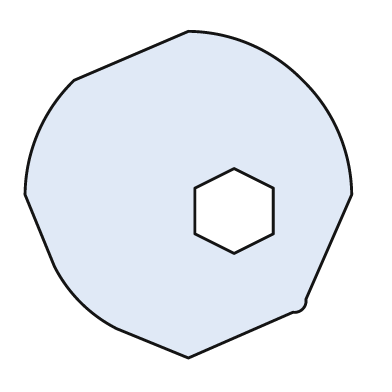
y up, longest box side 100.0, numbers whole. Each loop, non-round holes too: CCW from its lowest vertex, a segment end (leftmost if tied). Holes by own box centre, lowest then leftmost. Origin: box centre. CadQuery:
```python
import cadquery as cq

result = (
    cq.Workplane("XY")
    .moveTo(0.0, -50.0)
    .lineTo(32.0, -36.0)
    .threePointArc((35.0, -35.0), (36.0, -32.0))
    .lineTo(50.0, 0.0)
    .threePointArc((46.0, 19.0), (35.0, 35.0))
    .threePointArc((19.0, 46.0), (0.0, 50.0))
    .lineTo(-35.0, 35.0)
    .threePointArc((-46.0, 19.0), (-50.0, 0.0))
    .lineTo(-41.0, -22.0)
    .threePointArc((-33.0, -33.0), (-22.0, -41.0))
    .close()
    .moveTo(14.0, -18.0)
    .lineTo(26.0, -12.0)
    .lineTo(26.0, 2.0)
    .lineTo(14.0, 8.0)
    .lineTo(2.0, 2.0)
    .lineTo(2.0, -12.0)
    .close()
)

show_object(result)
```